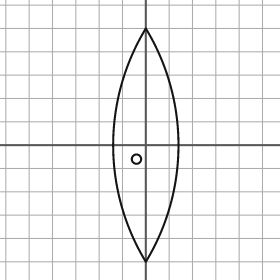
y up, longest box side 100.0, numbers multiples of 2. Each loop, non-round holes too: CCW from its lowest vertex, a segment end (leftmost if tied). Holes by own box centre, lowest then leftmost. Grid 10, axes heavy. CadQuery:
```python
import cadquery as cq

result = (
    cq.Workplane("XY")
    .moveTo(0.0, -50.0)
    .threePointArc((14.0, 0.0), (0.0, 50.0))
    .threePointArc((-14.0, 0.0), (0.0, -50.0))
    .close()
    .moveTo(-4.0, -6.0)
    .circle(2.0)
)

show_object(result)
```